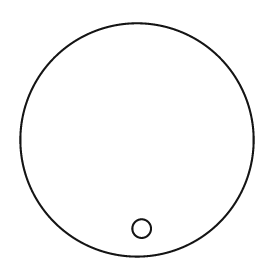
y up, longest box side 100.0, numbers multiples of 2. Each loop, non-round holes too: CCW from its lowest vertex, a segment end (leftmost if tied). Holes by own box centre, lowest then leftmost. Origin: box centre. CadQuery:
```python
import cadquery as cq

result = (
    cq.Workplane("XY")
    .moveTo(0.0, 0.0)
    .circle(50.0)
    .moveTo(2.0, -38.0)
    .circle(4.0)
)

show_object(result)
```